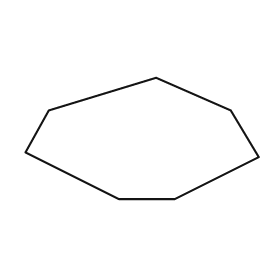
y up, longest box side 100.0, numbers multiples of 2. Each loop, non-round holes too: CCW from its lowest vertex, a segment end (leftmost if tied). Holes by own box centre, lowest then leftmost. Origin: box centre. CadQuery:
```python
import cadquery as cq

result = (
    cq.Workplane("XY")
    .moveTo(-10.0, -26.0)
    .lineTo(14.0, -26.0)
    .lineTo(50.0, -8.0)
    .lineTo(38.0, 12.0)
    .lineTo(6.0, 26.0)
    .lineTo(-40.0, 12.0)
    .lineTo(-50.0, -6.0)
    .close()
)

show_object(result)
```